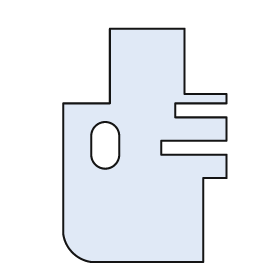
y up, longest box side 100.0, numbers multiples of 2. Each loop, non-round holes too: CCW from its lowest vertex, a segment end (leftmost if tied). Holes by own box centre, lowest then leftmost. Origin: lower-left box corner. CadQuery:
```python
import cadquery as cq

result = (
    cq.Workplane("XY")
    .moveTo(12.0, 0.0)
    .lineTo(60.0, 0.0)
    .lineTo(60.0, 36.0)
    .lineTo(70.0, 36.0)
    .lineTo(70.0, 46.0)
    .lineTo(42.0, 46.0)
    .lineTo(42.0, 52.0)
    .lineTo(70.0, 52.0)
    .lineTo(70.0, 62.0)
    .lineTo(48.0, 62.0)
    .lineTo(48.0, 68.0)
    .lineTo(70.0, 68.0)
    .lineTo(70.0, 72.0)
    .lineTo(52.0, 72.0)
    .lineTo(52.0, 100.0)
    .lineTo(20.0, 100.0)
    .lineTo(20.0, 68.0)
    .lineTo(0.0, 68.0)
    .lineTo(0.0, 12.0)
    .threePointArc((4.0, 4.0), (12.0, 0.0))
    .close()
    .moveTo(12.0, 46.0)
    .threePointArc((18.0, 40.0), (24.0, 46.0))
    .lineTo(24.0, 54.0)
    .threePointArc((18.0, 60.0), (12.0, 54.0))
    .close()
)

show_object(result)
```